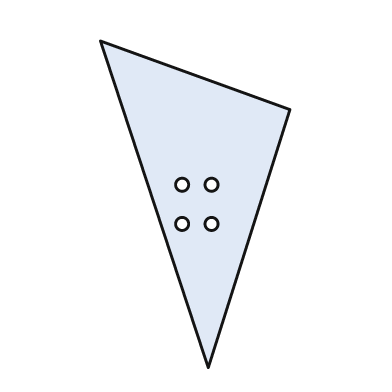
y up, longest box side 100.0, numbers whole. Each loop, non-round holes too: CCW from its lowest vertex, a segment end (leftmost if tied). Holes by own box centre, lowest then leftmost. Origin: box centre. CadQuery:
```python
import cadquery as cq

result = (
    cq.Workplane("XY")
    .moveTo(4.0, -50.0)
    .lineTo(29.0, 29.0)
    .lineTo(-29.0, 50.0)
    .close()
    .moveTo(-4.0, -6.0)
    .circle(2.0)
    .moveTo(5.0, -6.0)
    .circle(2.0)
    .moveTo(-4.0, 6.0)
    .circle(2.0)
    .moveTo(5.0, 6.0)
    .circle(2.0)
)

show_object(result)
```